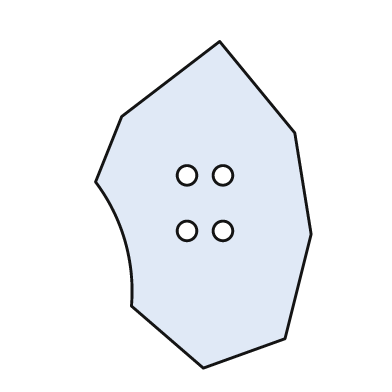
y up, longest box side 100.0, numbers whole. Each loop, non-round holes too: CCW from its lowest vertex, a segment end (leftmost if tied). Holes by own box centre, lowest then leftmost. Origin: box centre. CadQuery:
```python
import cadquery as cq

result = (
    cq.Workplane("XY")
    .moveTo(0.0, -50.0)
    .lineTo(25.0, -41.0)
    .lineTo(33.0, -9.0)
    .lineTo(28.0, 22.0)
    .lineTo(5.0, 50.0)
    .lineTo(-25.0, 27.0)
    .lineTo(-33.0, 7.0)
    .threePointArc((-24.0, -11.0), (-22.0, -31.0))
    .close()
    .moveTo(-5.0, -8.0)
    .circle(3.0)
    .moveTo(6.0, -8.0)
    .circle(3.0)
    .moveTo(-5.0, 9.0)
    .circle(3.0)
    .moveTo(6.0, 9.0)
    .circle(3.0)
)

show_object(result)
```